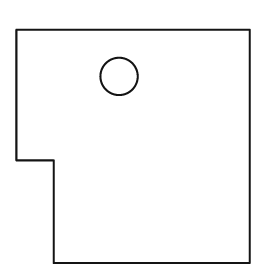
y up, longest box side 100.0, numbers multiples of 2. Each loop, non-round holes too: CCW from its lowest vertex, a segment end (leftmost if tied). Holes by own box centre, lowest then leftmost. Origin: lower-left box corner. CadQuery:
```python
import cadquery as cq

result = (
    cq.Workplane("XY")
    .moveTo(16.0, 0.0)
    .lineTo(100.0, 0.0)
    .lineTo(100.0, 100.0)
    .lineTo(0.0, 100.0)
    .lineTo(0.0, 44.0)
    .lineTo(16.0, 44.0)
    .close()
    .moveTo(44.0, 80.0)
    .circle(8.0)
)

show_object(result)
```